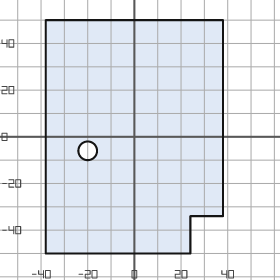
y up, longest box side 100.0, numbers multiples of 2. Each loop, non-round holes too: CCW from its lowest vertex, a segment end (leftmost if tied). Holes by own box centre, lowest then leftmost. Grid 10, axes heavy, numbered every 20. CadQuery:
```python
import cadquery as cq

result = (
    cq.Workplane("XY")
    .moveTo(-38.0, -50.0)
    .lineTo(24.0, -50.0)
    .lineTo(24.0, -34.0)
    .lineTo(38.0, -34.0)
    .lineTo(38.0, 50.0)
    .lineTo(-38.0, 50.0)
    .close()
    .moveTo(-20.0, -6.0)
    .circle(4.0)
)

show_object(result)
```